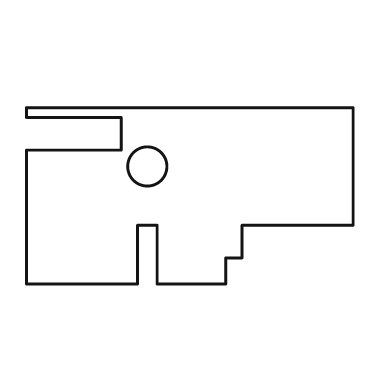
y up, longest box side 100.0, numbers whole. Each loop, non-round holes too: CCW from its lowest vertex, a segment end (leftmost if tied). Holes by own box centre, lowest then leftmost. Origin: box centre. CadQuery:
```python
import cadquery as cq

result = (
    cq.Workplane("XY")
    .moveTo(-50.0, -27.0)
    .lineTo(-16.0, -27.0)
    .lineTo(-16.0, -9.0)
    .lineTo(-10.0, -9.0)
    .lineTo(-10.0, -27.0)
    .lineTo(11.0, -27.0)
    .lineTo(11.0, -19.0)
    .lineTo(16.0, -19.0)
    .lineTo(16.0, -9.0)
    .lineTo(50.0, -9.0)
    .lineTo(50.0, 27.0)
    .lineTo(-50.0, 27.0)
    .lineTo(-50.0, 24.0)
    .lineTo(-21.0, 24.0)
    .lineTo(-21.0, 14.0)
    .lineTo(-50.0, 14.0)
    .close()
    .moveTo(-13.0, 9.0)
    .circle(6.0)
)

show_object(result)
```